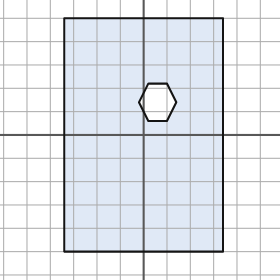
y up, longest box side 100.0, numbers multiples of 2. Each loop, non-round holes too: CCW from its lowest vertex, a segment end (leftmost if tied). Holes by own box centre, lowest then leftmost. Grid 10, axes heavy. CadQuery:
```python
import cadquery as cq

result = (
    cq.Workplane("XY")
    .moveTo(-34.0, -50.0)
    .lineTo(34.0, -50.0)
    .lineTo(34.0, 50.0)
    .lineTo(-34.0, 50.0)
    .close()
    .moveTo(2.0, 6.0)
    .lineTo(10.0, 6.0)
    .lineTo(14.0, 14.0)
    .lineTo(10.0, 22.0)
    .lineTo(2.0, 22.0)
    .lineTo(-2.0, 14.0)
    .close()
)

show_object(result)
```